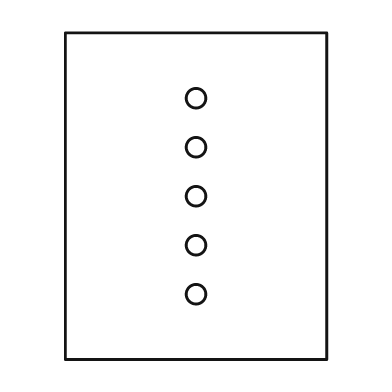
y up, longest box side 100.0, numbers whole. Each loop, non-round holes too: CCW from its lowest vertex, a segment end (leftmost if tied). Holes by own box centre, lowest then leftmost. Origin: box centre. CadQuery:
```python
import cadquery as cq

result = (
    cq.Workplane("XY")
    .moveTo(-40.0, -50.0)
    .lineTo(40.0, -50.0)
    .lineTo(40.0, 50.0)
    .lineTo(-40.0, 50.0)
    .close()
    .moveTo(0.0, -30.0)
    .circle(3.0)
    .moveTo(0.0, -15.0)
    .circle(3.0)
    .moveTo(0.0, 0.0)
    .circle(3.0)
    .moveTo(0.0, 15.0)
    .circle(3.0)
    .moveTo(0.0, 30.0)
    .circle(3.0)
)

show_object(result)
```